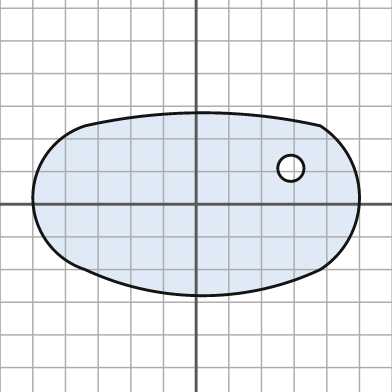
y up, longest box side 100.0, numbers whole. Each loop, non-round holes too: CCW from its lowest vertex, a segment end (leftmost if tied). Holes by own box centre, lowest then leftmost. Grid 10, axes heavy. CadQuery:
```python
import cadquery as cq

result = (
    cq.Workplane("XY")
    .moveTo(-34.0, -20.0)
    .threePointArc((2.0, -28.0), (38.0, -20.0))
    .threePointArc((50.0, 2.0), (38.0, 24.0))
    .threePointArc((2.0, 28.0), (-34.0, 24.0))
    .threePointArc((-50.0, 2.0), (-34.0, -20.0))
    .close()
    .moveTo(29.0, 11.0)
    .circle(4.0)
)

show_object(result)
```